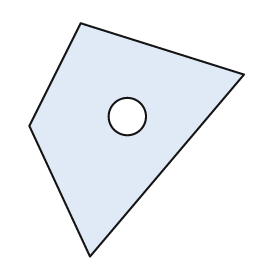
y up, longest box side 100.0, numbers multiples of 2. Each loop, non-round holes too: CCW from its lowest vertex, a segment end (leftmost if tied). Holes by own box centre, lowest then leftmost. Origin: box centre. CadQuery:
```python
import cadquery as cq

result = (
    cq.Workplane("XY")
    .moveTo(-20.0, -50.0)
    .lineTo(46.0, 28.0)
    .lineTo(-24.0, 50.0)
    .lineTo(-46.0, 6.0)
    .close()
    .moveTo(-4.0, 10.0)
    .circle(8.0)
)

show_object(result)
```